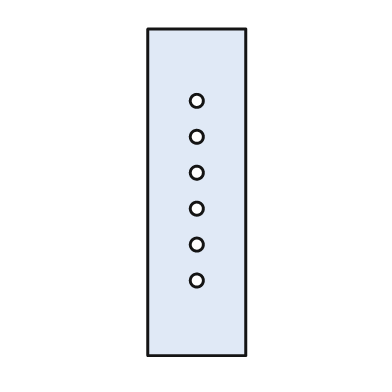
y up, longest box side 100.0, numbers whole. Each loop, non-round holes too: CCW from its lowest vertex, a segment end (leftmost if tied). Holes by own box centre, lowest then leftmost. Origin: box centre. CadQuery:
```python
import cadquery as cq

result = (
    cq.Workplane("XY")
    .moveTo(-15.0, -50.0)
    .lineTo(15.0, -50.0)
    .lineTo(15.0, 50.0)
    .lineTo(-15.0, 50.0)
    .close()
    .moveTo(0.0, -27.0)
    .circle(2.0)
    .moveTo(0.0, -16.0)
    .circle(2.0)
    .moveTo(0.0, -5.0)
    .circle(2.0)
    .moveTo(0.0, 6.0)
    .circle(2.0)
    .moveTo(0.0, 17.0)
    .circle(2.0)
    .moveTo(0.0, 28.0)
    .circle(2.0)
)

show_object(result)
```